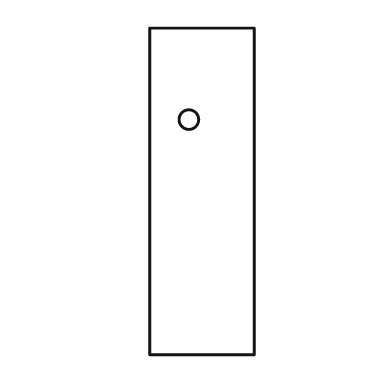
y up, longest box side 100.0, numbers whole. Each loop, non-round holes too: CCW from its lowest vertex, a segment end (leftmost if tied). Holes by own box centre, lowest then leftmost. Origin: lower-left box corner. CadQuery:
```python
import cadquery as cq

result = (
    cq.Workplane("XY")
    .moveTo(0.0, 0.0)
    .lineTo(32.0, 0.0)
    .lineTo(32.0, 100.0)
    .lineTo(0.0, 100.0)
    .close()
    .moveTo(12.0, 72.0)
    .circle(3.0)
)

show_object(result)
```